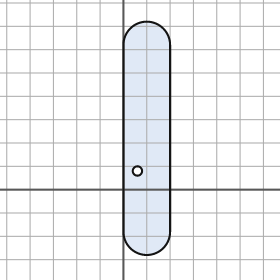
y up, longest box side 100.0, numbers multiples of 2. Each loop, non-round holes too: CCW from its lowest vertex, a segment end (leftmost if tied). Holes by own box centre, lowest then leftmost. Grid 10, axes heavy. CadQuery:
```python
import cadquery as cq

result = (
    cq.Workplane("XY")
    .moveTo(0.0, -18.0)
    .threePointArc((10.0, -28.0), (20.0, -18.0))
    .lineTo(20.0, 62.0)
    .threePointArc((10.0, 72.0), (0.0, 62.0))
    .close()
    .moveTo(6.0, 8.0)
    .circle(2.0)
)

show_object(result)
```